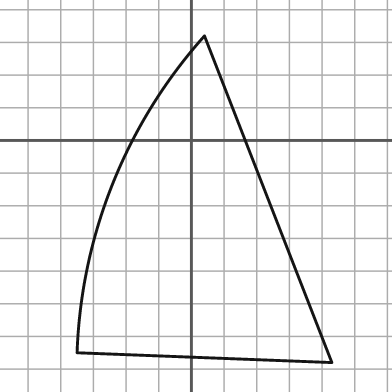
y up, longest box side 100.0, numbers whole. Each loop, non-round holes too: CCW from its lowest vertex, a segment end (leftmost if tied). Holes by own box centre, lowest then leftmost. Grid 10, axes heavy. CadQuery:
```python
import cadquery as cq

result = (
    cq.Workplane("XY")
    .moveTo(43.0, -68.0)
    .lineTo(4.0, 32.0)
    .threePointArc((-24.0, -13.0), (-35.0, -65.0))
    .close()
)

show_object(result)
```